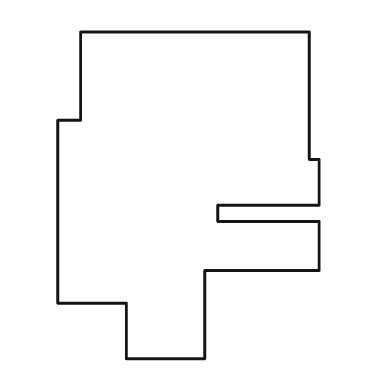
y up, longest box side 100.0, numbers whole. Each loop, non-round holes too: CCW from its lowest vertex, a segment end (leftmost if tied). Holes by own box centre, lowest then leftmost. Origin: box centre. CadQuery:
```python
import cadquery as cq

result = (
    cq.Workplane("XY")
    .moveTo(-19.0, -50.0)
    .lineTo(5.0, -50.0)
    .lineTo(5.0, -23.0)
    .lineTo(40.0, -23.0)
    .lineTo(40.0, -8.0)
    .lineTo(9.0, -8.0)
    .lineTo(9.0, -3.0)
    .lineTo(40.0, -3.0)
    .lineTo(40.0, 11.0)
    .lineTo(37.0, 11.0)
    .lineTo(37.0, 50.0)
    .lineTo(-33.0, 50.0)
    .lineTo(-33.0, 23.0)
    .lineTo(-40.0, 23.0)
    .lineTo(-40.0, -33.0)
    .lineTo(-19.0, -33.0)
    .close()
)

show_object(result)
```